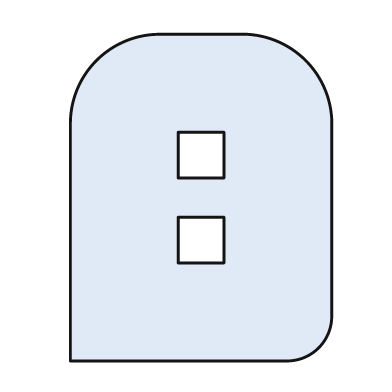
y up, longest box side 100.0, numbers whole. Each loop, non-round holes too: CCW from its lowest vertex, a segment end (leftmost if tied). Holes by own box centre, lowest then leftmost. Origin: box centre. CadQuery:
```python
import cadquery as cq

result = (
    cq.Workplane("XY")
    .moveTo(-40.0, -50.0)
    .lineTo(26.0, -50.0)
    .threePointArc((36.0, -46.0), (40.0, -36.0))
    .lineTo(40.0, 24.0)
    .threePointArc((32.0, 42.0), (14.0, 50.0))
    .lineTo(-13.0, 50.0)
    .threePointArc((-32.0, 42.0), (-40.0, 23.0))
    .close()
    .moveTo(-7.0, -20.0)
    .lineTo(7.0, -20.0)
    .lineTo(7.0, -6.0)
    .lineTo(-7.0, -6.0)
    .close()
    .moveTo(-7.0, 6.0)
    .lineTo(7.0, 6.0)
    .lineTo(7.0, 20.0)
    .lineTo(-7.0, 20.0)
    .close()
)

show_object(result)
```